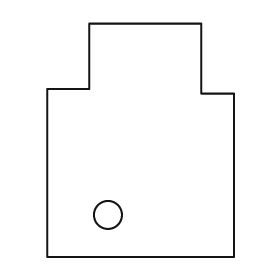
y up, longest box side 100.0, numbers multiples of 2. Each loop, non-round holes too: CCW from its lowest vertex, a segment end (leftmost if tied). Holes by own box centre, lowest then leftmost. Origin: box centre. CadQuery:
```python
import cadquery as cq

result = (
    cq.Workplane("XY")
    .moveTo(-40.0, -50.0)
    .lineTo(40.0, -50.0)
    .lineTo(40.0, 20.0)
    .lineTo(26.0, 20.0)
    .lineTo(26.0, 50.0)
    .lineTo(-22.0, 50.0)
    .lineTo(-22.0, 22.0)
    .lineTo(-40.0, 22.0)
    .close()
    .moveTo(-14.0, -32.0)
    .circle(6.0)
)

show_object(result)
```